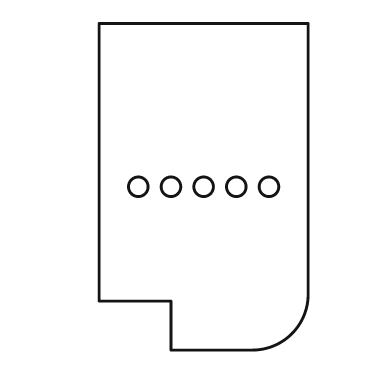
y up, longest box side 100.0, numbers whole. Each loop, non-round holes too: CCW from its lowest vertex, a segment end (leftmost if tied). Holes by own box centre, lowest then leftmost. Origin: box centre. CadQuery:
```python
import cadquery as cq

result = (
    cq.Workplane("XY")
    .moveTo(-10.0, -50.0)
    .lineTo(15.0, -50.0)
    .threePointArc((27.0, -45.0), (32.0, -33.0))
    .lineTo(32.0, 50.0)
    .lineTo(-32.0, 50.0)
    .lineTo(-32.0, -35.0)
    .lineTo(-10.0, -35.0)
    .close()
    .moveTo(-20.0, 0.0)
    .circle(3.0)
    .moveTo(-10.0, 0.0)
    .circle(3.0)
    .moveTo(0.0, 0.0)
    .circle(3.0)
    .moveTo(10.0, 0.0)
    .circle(3.0)
    .moveTo(20.0, 0.0)
    .circle(3.0)
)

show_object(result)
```